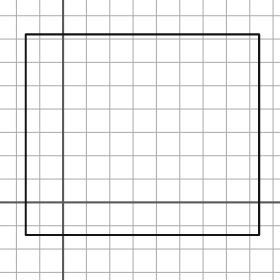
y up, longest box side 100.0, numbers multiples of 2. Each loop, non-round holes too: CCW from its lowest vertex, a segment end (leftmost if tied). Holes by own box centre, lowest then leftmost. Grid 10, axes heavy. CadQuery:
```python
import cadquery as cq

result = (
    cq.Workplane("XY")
    .moveTo(-16.0, -14.0)
    .lineTo(84.0, -14.0)
    .lineTo(84.0, 72.0)
    .lineTo(-16.0, 72.0)
    .close()
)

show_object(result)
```